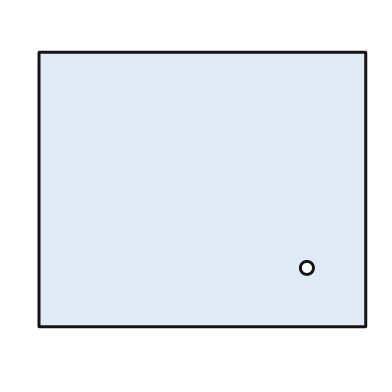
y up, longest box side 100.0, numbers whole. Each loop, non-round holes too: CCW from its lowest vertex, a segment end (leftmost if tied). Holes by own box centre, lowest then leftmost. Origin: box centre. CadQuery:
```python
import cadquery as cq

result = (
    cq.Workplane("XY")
    .moveTo(-50.0, -42.0)
    .lineTo(50.0, -42.0)
    .lineTo(50.0, 42.0)
    .lineTo(-50.0, 42.0)
    .close()
    .moveTo(32.0, -24.0)
    .circle(2.0)
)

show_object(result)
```